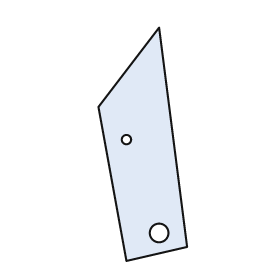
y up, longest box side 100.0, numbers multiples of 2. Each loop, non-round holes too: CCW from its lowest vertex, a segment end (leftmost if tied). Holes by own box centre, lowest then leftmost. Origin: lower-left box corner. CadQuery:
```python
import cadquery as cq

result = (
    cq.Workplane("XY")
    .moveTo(12.0, 0.0)
    .lineTo(38.0, 6.0)
    .lineTo(26.0, 100.0)
    .lineTo(0.0, 66.0)
    .close()
    .moveTo(26.0, 12.0)
    .circle(4.0)
    .moveTo(12.0, 52.0)
    .circle(2.0)
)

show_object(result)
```